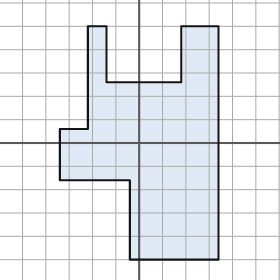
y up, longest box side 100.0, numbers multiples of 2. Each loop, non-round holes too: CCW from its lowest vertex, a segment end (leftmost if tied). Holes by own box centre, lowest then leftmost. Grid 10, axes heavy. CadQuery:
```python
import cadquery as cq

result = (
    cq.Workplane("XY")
    .moveTo(-4.0, -50.0)
    .lineTo(34.0, -50.0)
    .lineTo(34.0, 50.0)
    .lineTo(18.0, 50.0)
    .lineTo(18.0, 26.0)
    .lineTo(-14.0, 26.0)
    .lineTo(-14.0, 50.0)
    .lineTo(-22.0, 50.0)
    .lineTo(-22.0, 6.0)
    .lineTo(-34.0, 6.0)
    .lineTo(-34.0, -16.0)
    .lineTo(-4.0, -16.0)
    .close()
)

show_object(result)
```